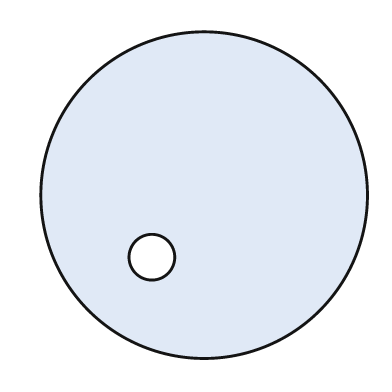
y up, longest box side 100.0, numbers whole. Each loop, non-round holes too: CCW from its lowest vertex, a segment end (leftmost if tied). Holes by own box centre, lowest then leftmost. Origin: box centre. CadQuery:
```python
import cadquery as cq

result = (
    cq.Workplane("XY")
    .moveTo(0.0, 0.0)
    .circle(50.0)
    .moveTo(-16.0, -19.0)
    .circle(7.0)
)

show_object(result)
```